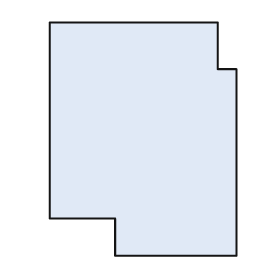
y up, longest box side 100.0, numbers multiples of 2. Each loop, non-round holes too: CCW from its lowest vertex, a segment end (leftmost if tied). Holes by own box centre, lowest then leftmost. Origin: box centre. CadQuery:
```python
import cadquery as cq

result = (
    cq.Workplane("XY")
    .moveTo(-12.0, -50.0)
    .lineTo(40.0, -50.0)
    .lineTo(40.0, 30.0)
    .lineTo(32.0, 30.0)
    .lineTo(32.0, 50.0)
    .lineTo(-40.0, 50.0)
    .lineTo(-40.0, -34.0)
    .lineTo(-12.0, -34.0)
    .close()
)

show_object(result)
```